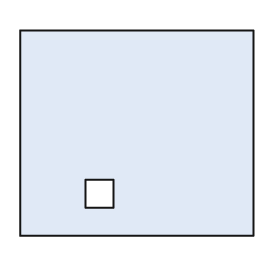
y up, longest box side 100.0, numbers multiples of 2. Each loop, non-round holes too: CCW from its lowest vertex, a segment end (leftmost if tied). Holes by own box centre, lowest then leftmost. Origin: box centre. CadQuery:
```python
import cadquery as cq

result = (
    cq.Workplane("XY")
    .moveTo(-50.0, -44.0)
    .lineTo(50.0, -44.0)
    .lineTo(50.0, 44.0)
    .lineTo(-50.0, 44.0)
    .close()
    .moveTo(-22.0, -32.0)
    .lineTo(-10.0, -32.0)
    .lineTo(-10.0, -20.0)
    .lineTo(-22.0, -20.0)
    .close()
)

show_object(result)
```